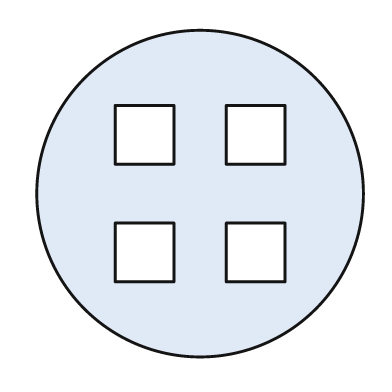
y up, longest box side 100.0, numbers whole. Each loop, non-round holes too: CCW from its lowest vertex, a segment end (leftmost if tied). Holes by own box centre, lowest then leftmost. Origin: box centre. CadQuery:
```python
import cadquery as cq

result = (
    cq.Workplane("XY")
    .moveTo(0.0, 0.0)
    .circle(50.0)
    .moveTo(-26.0, -27.0)
    .lineTo(-8.0, -27.0)
    .lineTo(-8.0, -9.0)
    .lineTo(-26.0, -9.0)
    .close()
    .moveTo(8.0, -27.0)
    .lineTo(26.0, -27.0)
    .lineTo(26.0, -9.0)
    .lineTo(8.0, -9.0)
    .close()
    .moveTo(-26.0, 9.0)
    .lineTo(-8.0, 9.0)
    .lineTo(-8.0, 27.0)
    .lineTo(-26.0, 27.0)
    .close()
    .moveTo(8.0, 9.0)
    .lineTo(26.0, 9.0)
    .lineTo(26.0, 27.0)
    .lineTo(8.0, 27.0)
    .close()
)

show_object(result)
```